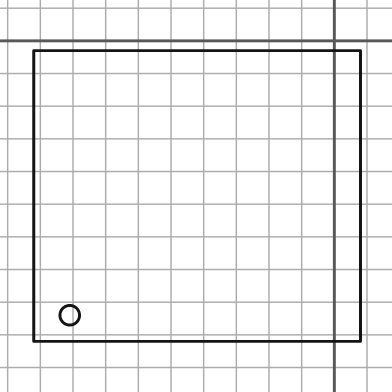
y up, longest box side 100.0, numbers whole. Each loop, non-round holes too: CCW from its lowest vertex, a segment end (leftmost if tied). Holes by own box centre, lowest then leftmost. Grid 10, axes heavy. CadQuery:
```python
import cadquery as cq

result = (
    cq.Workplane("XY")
    .moveTo(-92.0, -92.0)
    .lineTo(8.0, -92.0)
    .lineTo(8.0, -3.0)
    .lineTo(-92.0, -3.0)
    .close()
    .moveTo(-81.0, -84.0)
    .circle(3.0)
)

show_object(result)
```